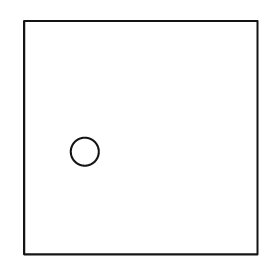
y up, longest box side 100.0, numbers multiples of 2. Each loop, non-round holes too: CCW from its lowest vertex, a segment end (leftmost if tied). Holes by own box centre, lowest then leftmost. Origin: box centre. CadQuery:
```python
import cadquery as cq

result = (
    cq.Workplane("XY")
    .moveTo(-50.0, -50.0)
    .lineTo(50.0, -50.0)
    .lineTo(50.0, 50.0)
    .lineTo(-50.0, 50.0)
    .close()
    .moveTo(-24.0, -6.0)
    .circle(6.0)
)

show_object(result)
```